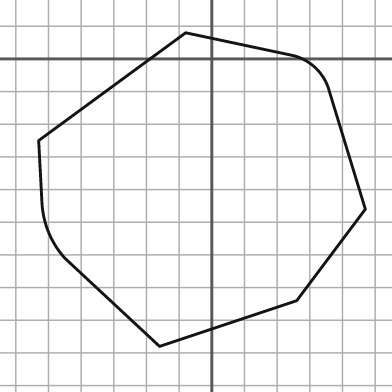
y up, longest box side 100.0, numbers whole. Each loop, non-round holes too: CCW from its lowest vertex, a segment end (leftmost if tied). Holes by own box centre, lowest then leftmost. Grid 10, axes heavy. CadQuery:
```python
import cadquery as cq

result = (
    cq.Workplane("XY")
    .moveTo(-16.0, -88.0)
    .lineTo(26.0, -74.0)
    .lineTo(47.0, -46.0)
    .lineTo(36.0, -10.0)
    .threePointArc((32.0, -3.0), (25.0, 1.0))
    .lineTo(-8.0, 8.0)
    .lineTo(-53.0, -25.0)
    .lineTo(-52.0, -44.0)
    .threePointArc((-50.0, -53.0), (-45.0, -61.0))
    .close()
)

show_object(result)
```